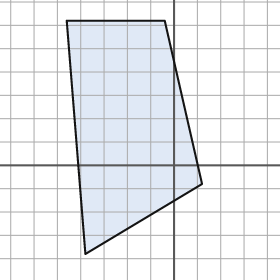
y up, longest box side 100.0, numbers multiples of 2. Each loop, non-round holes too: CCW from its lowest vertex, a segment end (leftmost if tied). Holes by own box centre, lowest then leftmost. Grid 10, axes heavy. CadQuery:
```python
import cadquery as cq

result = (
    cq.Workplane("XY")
    .moveTo(-38.0, -38.0)
    .lineTo(12.0, -8.0)
    .lineTo(-4.0, 62.0)
    .lineTo(-46.0, 62.0)
    .close()
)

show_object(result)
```